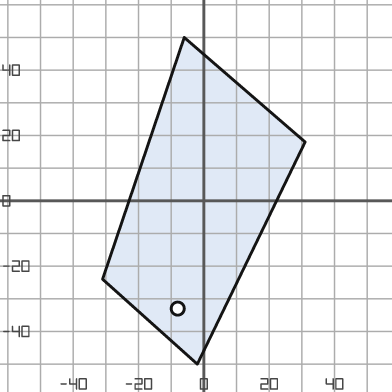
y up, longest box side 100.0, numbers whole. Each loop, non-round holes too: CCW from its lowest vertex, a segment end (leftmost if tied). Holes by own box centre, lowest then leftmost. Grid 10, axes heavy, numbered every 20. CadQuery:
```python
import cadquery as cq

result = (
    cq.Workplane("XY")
    .moveTo(-2.0, -50.0)
    .lineTo(31.0, 18.0)
    .lineTo(-6.0, 50.0)
    .lineTo(-31.0, -24.0)
    .close()
    .moveTo(-8.0, -33.0)
    .circle(2.0)
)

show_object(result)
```